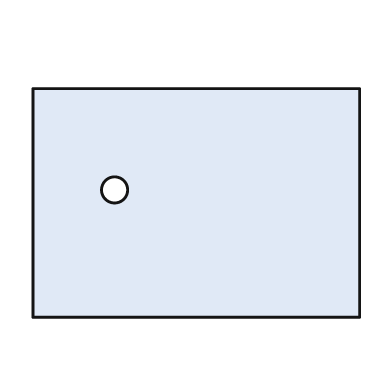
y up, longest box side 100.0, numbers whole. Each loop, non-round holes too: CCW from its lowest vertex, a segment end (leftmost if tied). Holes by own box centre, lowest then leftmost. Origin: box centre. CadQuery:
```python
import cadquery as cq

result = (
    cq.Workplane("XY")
    .moveTo(-50.0, -35.0)
    .lineTo(50.0, -35.0)
    .lineTo(50.0, 35.0)
    .lineTo(-50.0, 35.0)
    .close()
    .moveTo(-25.0, 4.0)
    .circle(4.0)
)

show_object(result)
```